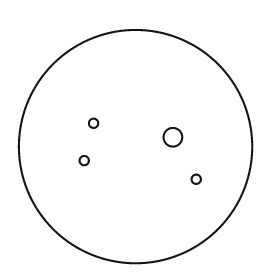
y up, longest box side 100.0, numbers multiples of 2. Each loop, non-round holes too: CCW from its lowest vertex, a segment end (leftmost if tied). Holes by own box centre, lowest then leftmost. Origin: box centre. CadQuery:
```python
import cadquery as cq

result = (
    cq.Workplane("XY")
    .moveTo(0.0, 0.0)
    .circle(50.0)
    .moveTo(26.0, -14.0)
    .circle(2.0)
    .moveTo(-22.0, -6.0)
    .circle(2.0)
    .moveTo(16.0, 4.0)
    .circle(4.0)
    .moveTo(-18.0, 10.0)
    .circle(2.0)
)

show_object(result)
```